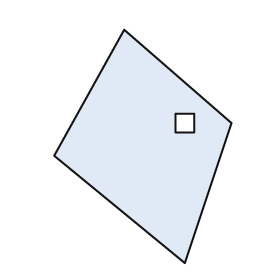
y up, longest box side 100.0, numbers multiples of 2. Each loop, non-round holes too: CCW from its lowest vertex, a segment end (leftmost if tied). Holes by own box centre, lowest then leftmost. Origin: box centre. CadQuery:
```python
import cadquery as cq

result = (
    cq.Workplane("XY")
    .moveTo(18.0, -50.0)
    .lineTo(38.0, 10.0)
    .lineTo(-8.0, 50.0)
    .lineTo(-38.0, -4.0)
    .close()
    .moveTo(14.0, 6.0)
    .lineTo(22.0, 6.0)
    .lineTo(22.0, 14.0)
    .lineTo(14.0, 14.0)
    .close()
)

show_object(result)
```